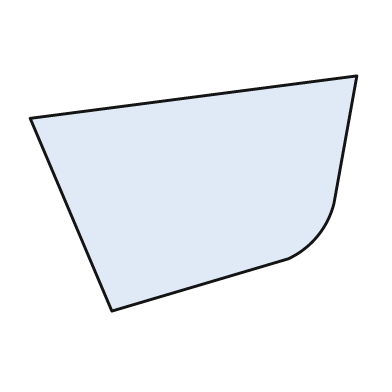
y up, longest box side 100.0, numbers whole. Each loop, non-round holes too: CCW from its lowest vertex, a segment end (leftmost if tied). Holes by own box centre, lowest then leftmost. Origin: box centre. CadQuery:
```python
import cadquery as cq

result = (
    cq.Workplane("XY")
    .moveTo(-25.0, -36.0)
    .lineTo(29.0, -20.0)
    .threePointArc((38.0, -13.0), (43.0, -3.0))
    .lineTo(50.0, 36.0)
    .lineTo(-50.0, 23.0)
    .close()
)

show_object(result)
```